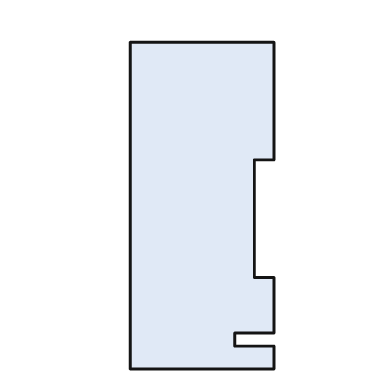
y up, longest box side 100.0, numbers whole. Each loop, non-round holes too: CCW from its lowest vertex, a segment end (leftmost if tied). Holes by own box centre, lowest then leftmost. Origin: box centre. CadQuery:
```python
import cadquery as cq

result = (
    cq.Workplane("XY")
    .moveTo(-22.0, -50.0)
    .lineTo(22.0, -50.0)
    .lineTo(22.0, -43.0)
    .lineTo(10.0, -43.0)
    .lineTo(10.0, -39.0)
    .lineTo(22.0, -39.0)
    .lineTo(22.0, -22.0)
    .lineTo(16.0, -22.0)
    .lineTo(16.0, 14.0)
    .lineTo(22.0, 14.0)
    .lineTo(22.0, 50.0)
    .lineTo(-22.0, 50.0)
    .close()
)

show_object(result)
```